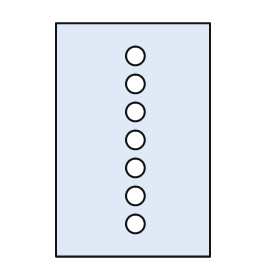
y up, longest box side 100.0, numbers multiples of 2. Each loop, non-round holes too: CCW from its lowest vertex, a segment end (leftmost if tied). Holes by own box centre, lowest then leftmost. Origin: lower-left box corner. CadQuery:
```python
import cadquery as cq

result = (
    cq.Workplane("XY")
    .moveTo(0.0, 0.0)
    .lineTo(66.0, 0.0)
    .lineTo(66.0, 100.0)
    .lineTo(0.0, 100.0)
    .close()
    .moveTo(34.0, 14.0)
    .circle(4.0)
    .moveTo(34.0, 26.0)
    .circle(4.0)
    .moveTo(34.0, 38.0)
    .circle(4.0)
    .moveTo(34.0, 50.0)
    .circle(4.0)
    .moveTo(34.0, 62.0)
    .circle(4.0)
    .moveTo(34.0, 74.0)
    .circle(4.0)
    .moveTo(34.0, 86.0)
    .circle(4.0)
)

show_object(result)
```